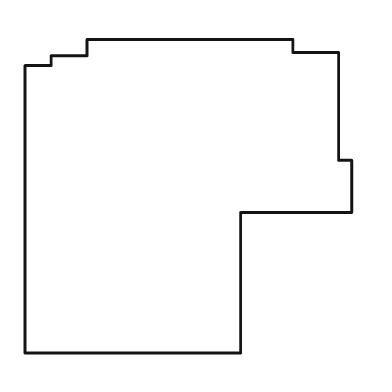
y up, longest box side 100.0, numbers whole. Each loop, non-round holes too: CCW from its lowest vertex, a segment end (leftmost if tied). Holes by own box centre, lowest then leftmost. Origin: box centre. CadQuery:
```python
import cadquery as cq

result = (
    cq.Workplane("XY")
    .moveTo(-50.0, -48.0)
    .lineTo(16.0, -48.0)
    .lineTo(16.0, -5.0)
    .lineTo(50.0, -5.0)
    .lineTo(50.0, 11.0)
    .lineTo(46.0, 11.0)
    .lineTo(46.0, 44.0)
    .lineTo(32.0, 44.0)
    .lineTo(32.0, 48.0)
    .lineTo(-31.0, 48.0)
    .lineTo(-31.0, 43.0)
    .lineTo(-42.0, 43.0)
    .lineTo(-42.0, 40.0)
    .lineTo(-50.0, 40.0)
    .close()
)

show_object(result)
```